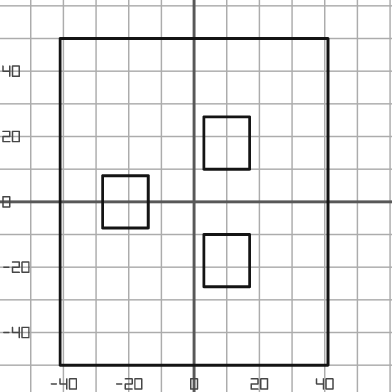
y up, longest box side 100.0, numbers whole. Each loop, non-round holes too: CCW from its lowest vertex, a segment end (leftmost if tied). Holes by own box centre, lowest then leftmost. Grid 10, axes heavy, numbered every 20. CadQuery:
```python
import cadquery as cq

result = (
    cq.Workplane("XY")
    .moveTo(-41.0, -50.0)
    .lineTo(41.0, -50.0)
    .lineTo(41.0, 50.0)
    .lineTo(-41.0, 50.0)
    .close()
    .moveTo(3.0, -26.0)
    .lineTo(17.0, -26.0)
    .lineTo(17.0, -10.0)
    .lineTo(3.0, -10.0)
    .close()
    .moveTo(-28.0, -8.0)
    .lineTo(-14.0, -8.0)
    .lineTo(-14.0, 8.0)
    .lineTo(-28.0, 8.0)
    .close()
    .moveTo(3.0, 10.0)
    .lineTo(17.0, 10.0)
    .lineTo(17.0, 26.0)
    .lineTo(3.0, 26.0)
    .close()
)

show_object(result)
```